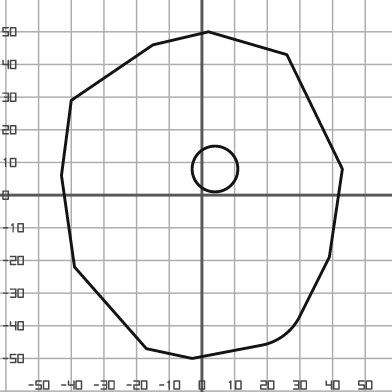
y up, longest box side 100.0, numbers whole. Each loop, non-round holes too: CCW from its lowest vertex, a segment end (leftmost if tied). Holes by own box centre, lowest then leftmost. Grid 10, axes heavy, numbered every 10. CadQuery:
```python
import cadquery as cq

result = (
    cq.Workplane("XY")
    .moveTo(-3.0, -50.0)
    .lineTo(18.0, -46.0)
    .threePointArc((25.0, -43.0), (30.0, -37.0))
    .lineTo(39.0, -19.0)
    .lineTo(43.0, 8.0)
    .lineTo(26.0, 43.0)
    .lineTo(2.0, 50.0)
    .lineTo(-15.0, 46.0)
    .lineTo(-40.0, 29.0)
    .lineTo(-43.0, 6.0)
    .lineTo(-39.0, -22.0)
    .lineTo(-17.0, -47.0)
    .close()
    .moveTo(4.0, 8.0)
    .circle(7.0)
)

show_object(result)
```